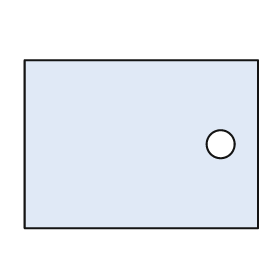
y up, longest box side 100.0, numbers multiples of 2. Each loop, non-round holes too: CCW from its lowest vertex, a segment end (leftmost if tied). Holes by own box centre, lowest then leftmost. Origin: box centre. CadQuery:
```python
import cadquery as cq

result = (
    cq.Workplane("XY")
    .moveTo(-50.0, -36.0)
    .lineTo(50.0, -36.0)
    .lineTo(50.0, 36.0)
    .lineTo(-50.0, 36.0)
    .close()
    .moveTo(34.0, 0.0)
    .circle(6.0)
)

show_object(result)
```